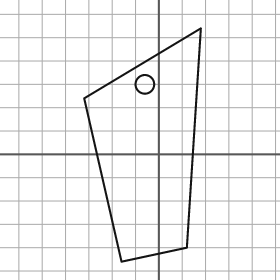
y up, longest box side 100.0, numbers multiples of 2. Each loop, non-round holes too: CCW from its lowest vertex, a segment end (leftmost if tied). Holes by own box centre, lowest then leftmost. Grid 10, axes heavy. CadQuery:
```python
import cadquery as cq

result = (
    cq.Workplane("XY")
    .moveTo(-16.0, -46.0)
    .lineTo(12.0, -40.0)
    .lineTo(18.0, 54.0)
    .lineTo(-32.0, 24.0)
    .close()
    .moveTo(-6.0, 30.0)
    .circle(4.0)
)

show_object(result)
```